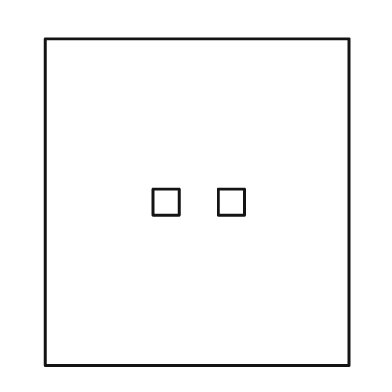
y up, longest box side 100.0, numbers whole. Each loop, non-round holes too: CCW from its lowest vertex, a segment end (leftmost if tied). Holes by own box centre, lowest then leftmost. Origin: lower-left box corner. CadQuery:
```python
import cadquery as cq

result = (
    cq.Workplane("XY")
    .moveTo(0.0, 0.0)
    .lineTo(93.0, 0.0)
    .lineTo(93.0, 100.0)
    .lineTo(0.0, 100.0)
    .close()
    .moveTo(33.0, 46.0)
    .lineTo(41.0, 46.0)
    .lineTo(41.0, 54.0)
    .lineTo(33.0, 54.0)
    .close()
    .moveTo(53.0, 46.0)
    .lineTo(61.0, 46.0)
    .lineTo(61.0, 54.0)
    .lineTo(53.0, 54.0)
    .close()
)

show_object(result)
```